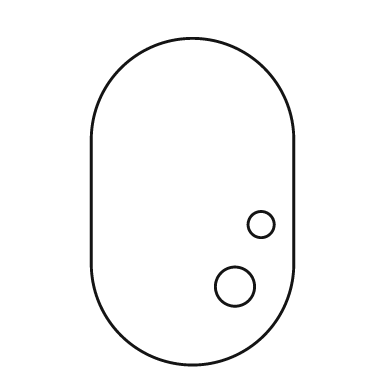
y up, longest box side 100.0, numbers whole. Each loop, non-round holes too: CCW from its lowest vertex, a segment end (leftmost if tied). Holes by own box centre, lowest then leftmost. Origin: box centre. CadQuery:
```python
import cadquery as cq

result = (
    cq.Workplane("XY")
    .moveTo(-31.0, -19.0)
    .threePointArc((0.0, -50.0), (31.0, -19.0))
    .lineTo(31.0, 19.0)
    .threePointArc((0.0, 50.0), (-31.0, 19.0))
    .close()
    .moveTo(13.0, -26.0)
    .circle(6.0)
    .moveTo(21.0, -7.0)
    .circle(4.0)
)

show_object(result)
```